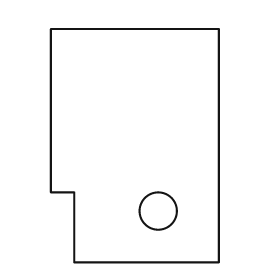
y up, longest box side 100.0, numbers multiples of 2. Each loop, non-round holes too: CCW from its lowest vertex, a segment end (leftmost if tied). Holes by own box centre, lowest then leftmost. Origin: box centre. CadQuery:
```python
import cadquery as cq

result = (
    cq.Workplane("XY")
    .moveTo(-26.0, -50.0)
    .lineTo(36.0, -50.0)
    .lineTo(36.0, 50.0)
    .lineTo(-36.0, 50.0)
    .lineTo(-36.0, -20.0)
    .lineTo(-26.0, -20.0)
    .close()
    .moveTo(10.0, -28.0)
    .circle(8.0)
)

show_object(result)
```